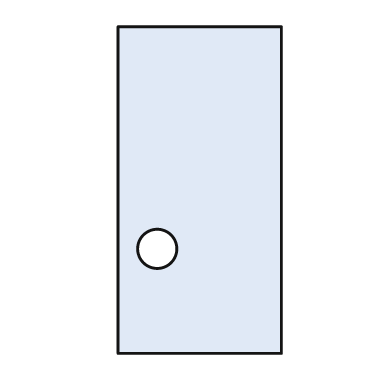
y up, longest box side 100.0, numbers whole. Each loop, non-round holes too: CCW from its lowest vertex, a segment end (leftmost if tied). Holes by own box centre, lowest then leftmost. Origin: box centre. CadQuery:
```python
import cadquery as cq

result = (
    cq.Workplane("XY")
    .moveTo(-25.0, -50.0)
    .lineTo(25.0, -50.0)
    .lineTo(25.0, 50.0)
    .lineTo(-25.0, 50.0)
    .close()
    .moveTo(-13.0, -18.0)
    .circle(6.0)
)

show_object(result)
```